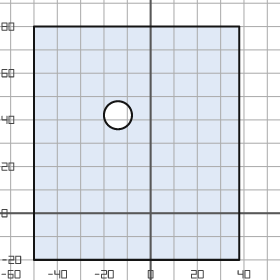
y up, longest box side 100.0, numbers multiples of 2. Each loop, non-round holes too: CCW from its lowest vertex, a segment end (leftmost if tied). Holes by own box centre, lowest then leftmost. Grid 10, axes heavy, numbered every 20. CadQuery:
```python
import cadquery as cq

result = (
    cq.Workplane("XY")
    .moveTo(-50.0, -20.0)
    .lineTo(38.0, -20.0)
    .lineTo(38.0, 80.0)
    .lineTo(-50.0, 80.0)
    .close()
    .moveTo(-14.0, 42.0)
    .circle(6.0)
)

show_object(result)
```